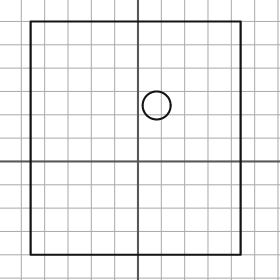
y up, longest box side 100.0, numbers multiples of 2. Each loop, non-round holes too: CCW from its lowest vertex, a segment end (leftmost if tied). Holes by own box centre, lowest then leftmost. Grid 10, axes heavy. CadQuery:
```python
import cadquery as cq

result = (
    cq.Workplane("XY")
    .moveTo(-46.0, -40.0)
    .lineTo(44.0, -40.0)
    .lineTo(44.0, 60.0)
    .lineTo(-46.0, 60.0)
    .close()
    .moveTo(8.0, 24.0)
    .circle(6.0)
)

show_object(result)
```